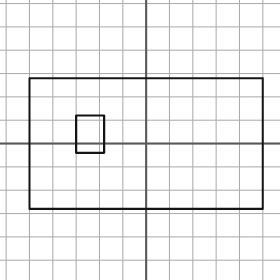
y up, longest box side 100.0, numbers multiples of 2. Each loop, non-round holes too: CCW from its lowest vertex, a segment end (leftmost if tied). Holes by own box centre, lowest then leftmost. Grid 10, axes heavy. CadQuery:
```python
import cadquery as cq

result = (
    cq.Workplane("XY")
    .moveTo(-50.0, -28.0)
    .lineTo(50.0, -28.0)
    .lineTo(50.0, 28.0)
    .lineTo(-50.0, 28.0)
    .close()
    .moveTo(-30.0, -4.0)
    .lineTo(-18.0, -4.0)
    .lineTo(-18.0, 12.0)
    .lineTo(-30.0, 12.0)
    .close()
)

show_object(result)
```